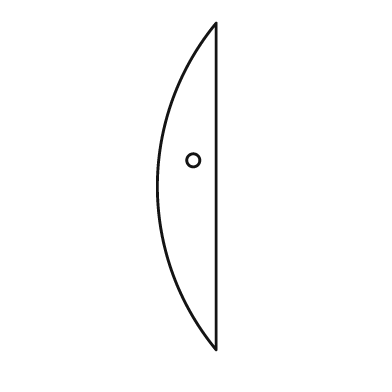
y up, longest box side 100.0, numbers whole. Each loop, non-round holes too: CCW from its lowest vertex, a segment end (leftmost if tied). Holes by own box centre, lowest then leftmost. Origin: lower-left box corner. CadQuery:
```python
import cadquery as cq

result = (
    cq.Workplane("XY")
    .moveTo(18.0, 0.0)
    .lineTo(18.0, 100.0)
    .threePointArc((0.0, 50.0), (18.0, 0.0))
    .close()
    .moveTo(11.0, 58.0)
    .circle(2.0)
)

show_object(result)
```